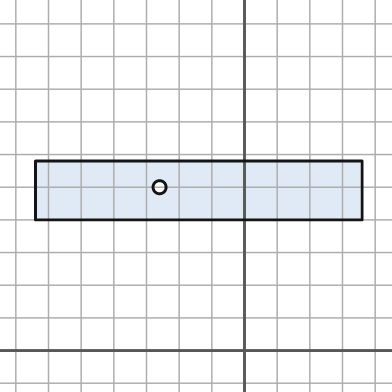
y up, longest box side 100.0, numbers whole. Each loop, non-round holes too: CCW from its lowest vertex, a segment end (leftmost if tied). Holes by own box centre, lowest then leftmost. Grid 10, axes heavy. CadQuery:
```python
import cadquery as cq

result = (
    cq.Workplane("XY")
    .moveTo(-64.0, 40.0)
    .lineTo(36.0, 40.0)
    .lineTo(36.0, 58.0)
    .lineTo(-64.0, 58.0)
    .close()
    .moveTo(-26.0, 50.0)
    .circle(2.0)
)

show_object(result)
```